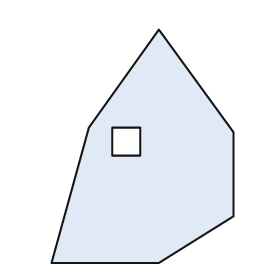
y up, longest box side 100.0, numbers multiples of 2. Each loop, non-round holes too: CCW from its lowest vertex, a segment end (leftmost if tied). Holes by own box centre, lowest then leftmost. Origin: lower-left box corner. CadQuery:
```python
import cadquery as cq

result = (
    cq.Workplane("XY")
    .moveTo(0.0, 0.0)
    .lineTo(46.0, 0.0)
    .lineTo(78.0, 20.0)
    .lineTo(78.0, 56.0)
    .lineTo(46.0, 100.0)
    .lineTo(16.0, 58.0)
    .close()
    .moveTo(26.0, 46.0)
    .lineTo(38.0, 46.0)
    .lineTo(38.0, 58.0)
    .lineTo(26.0, 58.0)
    .close()
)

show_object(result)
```